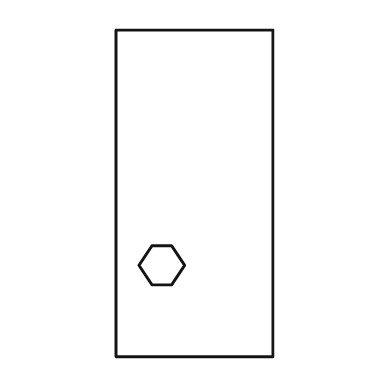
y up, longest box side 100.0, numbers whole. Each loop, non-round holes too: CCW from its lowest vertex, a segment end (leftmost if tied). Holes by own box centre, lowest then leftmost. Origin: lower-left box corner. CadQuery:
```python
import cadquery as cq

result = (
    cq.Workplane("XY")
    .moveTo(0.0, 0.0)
    .lineTo(48.0, 0.0)
    .lineTo(48.0, 100.0)
    .lineTo(0.0, 100.0)
    .close()
    .moveTo(11.0, 22.0)
    .lineTo(17.0, 22.0)
    .lineTo(21.0, 28.0)
    .lineTo(17.0, 34.0)
    .lineTo(11.0, 34.0)
    .lineTo(7.0, 28.0)
    .close()
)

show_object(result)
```